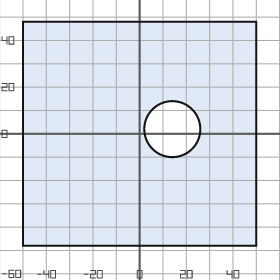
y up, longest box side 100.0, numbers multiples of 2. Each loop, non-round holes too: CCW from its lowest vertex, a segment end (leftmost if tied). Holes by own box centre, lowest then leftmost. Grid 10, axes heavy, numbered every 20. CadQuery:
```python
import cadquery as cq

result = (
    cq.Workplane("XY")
    .moveTo(-50.0, -48.0)
    .lineTo(50.0, -48.0)
    .lineTo(50.0, 48.0)
    .lineTo(-50.0, 48.0)
    .close()
    .moveTo(14.0, 2.0)
    .circle(12.0)
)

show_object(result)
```